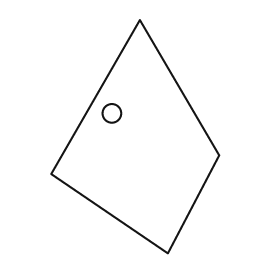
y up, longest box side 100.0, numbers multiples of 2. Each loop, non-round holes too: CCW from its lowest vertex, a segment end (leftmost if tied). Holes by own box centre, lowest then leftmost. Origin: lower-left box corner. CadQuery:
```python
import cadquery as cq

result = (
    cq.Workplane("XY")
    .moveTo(50.0, 0.0)
    .lineTo(72.0, 42.0)
    .lineTo(38.0, 100.0)
    .lineTo(0.0, 34.0)
    .close()
    .moveTo(26.0, 60.0)
    .circle(4.0)
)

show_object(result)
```